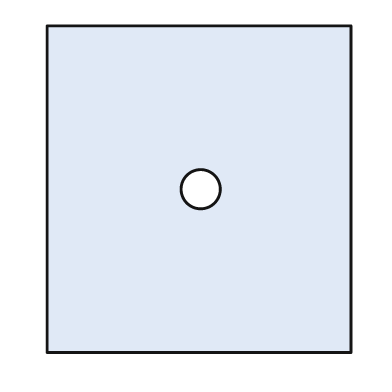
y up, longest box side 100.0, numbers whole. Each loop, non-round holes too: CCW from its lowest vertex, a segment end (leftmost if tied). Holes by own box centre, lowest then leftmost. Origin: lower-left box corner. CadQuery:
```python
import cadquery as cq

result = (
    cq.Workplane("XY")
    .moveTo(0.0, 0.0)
    .lineTo(93.0, 0.0)
    .lineTo(93.0, 100.0)
    .lineTo(0.0, 100.0)
    .close()
    .moveTo(47.0, 50.0)
    .circle(6.0)
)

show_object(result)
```